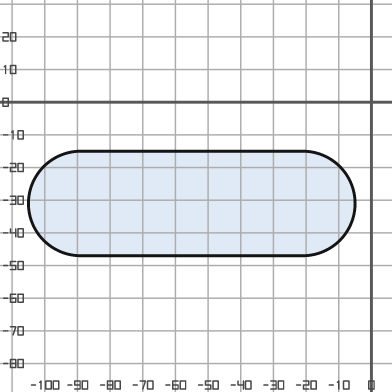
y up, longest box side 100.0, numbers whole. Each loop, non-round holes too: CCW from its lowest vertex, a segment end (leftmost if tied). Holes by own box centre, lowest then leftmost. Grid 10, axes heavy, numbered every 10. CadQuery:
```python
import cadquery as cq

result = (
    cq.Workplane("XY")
    .moveTo(-89.0, -47.0)
    .lineTo(-21.0, -47.0)
    .threePointArc((-5.0, -31.0), (-21.0, -15.0))
    .lineTo(-89.0, -15.0)
    .threePointArc((-105.0, -31.0), (-89.0, -47.0))
    .close()
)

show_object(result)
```